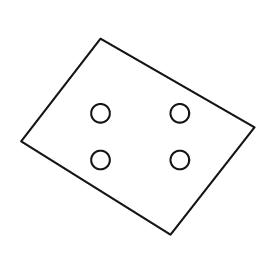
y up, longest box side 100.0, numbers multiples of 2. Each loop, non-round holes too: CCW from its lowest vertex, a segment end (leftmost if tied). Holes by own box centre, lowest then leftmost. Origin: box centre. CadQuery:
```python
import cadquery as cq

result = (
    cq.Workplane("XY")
    .moveTo(14.0, -42.0)
    .lineTo(50.0, 4.0)
    .lineTo(-16.0, 42.0)
    .lineTo(-50.0, -2.0)
    .close()
    .moveTo(-16.0, -10.0)
    .circle(4.0)
    .moveTo(18.0, -10.0)
    .circle(4.0)
    .moveTo(-16.0, 10.0)
    .circle(4.0)
    .moveTo(18.0, 10.0)
    .circle(4.0)
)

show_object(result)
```